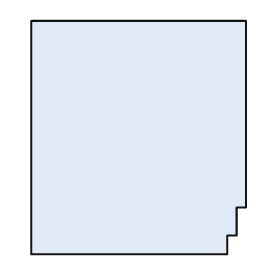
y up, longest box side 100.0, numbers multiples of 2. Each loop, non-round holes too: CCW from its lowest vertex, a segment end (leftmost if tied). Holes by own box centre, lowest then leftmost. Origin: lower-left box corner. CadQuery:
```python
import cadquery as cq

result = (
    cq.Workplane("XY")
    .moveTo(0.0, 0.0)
    .lineTo(84.0, 0.0)
    .lineTo(84.0, 8.0)
    .lineTo(88.0, 8.0)
    .lineTo(88.0, 20.0)
    .lineTo(92.0, 20.0)
    .lineTo(92.0, 100.0)
    .lineTo(0.0, 100.0)
    .close()
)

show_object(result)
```